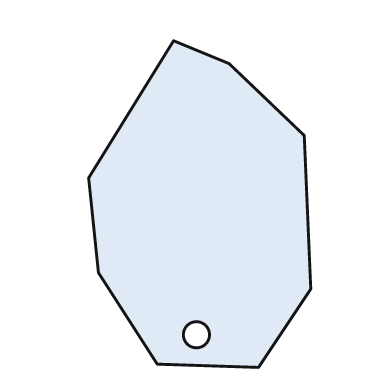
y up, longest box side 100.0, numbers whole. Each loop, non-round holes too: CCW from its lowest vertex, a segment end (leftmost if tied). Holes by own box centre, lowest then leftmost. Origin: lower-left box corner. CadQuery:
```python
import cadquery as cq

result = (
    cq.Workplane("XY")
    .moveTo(52.0, 0.0)
    .lineTo(68.0, 24.0)
    .lineTo(66.0, 71.0)
    .lineTo(43.0, 93.0)
    .lineTo(26.0, 100.0)
    .lineTo(0.0, 58.0)
    .lineTo(3.0, 29.0)
    .lineTo(21.0, 1.0)
    .close()
    .moveTo(33.0, 10.0)
    .circle(4.0)
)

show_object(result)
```